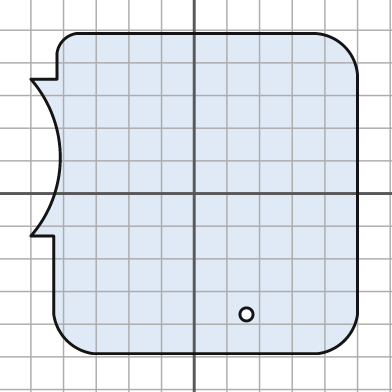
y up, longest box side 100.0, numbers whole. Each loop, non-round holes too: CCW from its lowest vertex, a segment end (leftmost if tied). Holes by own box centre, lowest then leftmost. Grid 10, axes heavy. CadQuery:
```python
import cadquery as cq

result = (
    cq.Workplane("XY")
    .moveTo(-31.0, -49.0)
    .lineTo(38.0, -49.0)
    .threePointArc((46.0, -45.0), (50.0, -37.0))
    .lineTo(50.0, 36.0)
    .threePointArc((46.0, 45.0), (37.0, 49.0))
    .lineTo(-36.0, 49.0)
    .threePointArc((-40.0, 47.0), (-42.0, 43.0))
    .lineTo(-42.0, 35.0)
    .lineTo(-50.0, 35.0)
    .threePointArc((-41.0, 11.0), (-50.0, -13.0))
    .lineTo(-43.0, -13.0)
    .lineTo(-43.0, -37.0)
    .threePointArc((-39.0, -45.0), (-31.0, -49.0))
    .close()
    .moveTo(16.0, -37.0)
    .circle(2.0)
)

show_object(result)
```